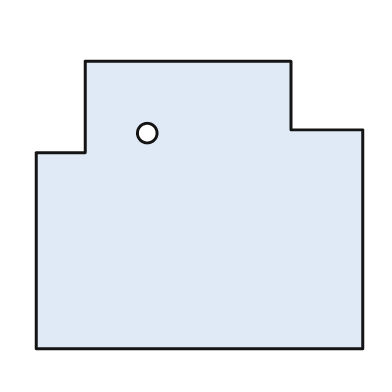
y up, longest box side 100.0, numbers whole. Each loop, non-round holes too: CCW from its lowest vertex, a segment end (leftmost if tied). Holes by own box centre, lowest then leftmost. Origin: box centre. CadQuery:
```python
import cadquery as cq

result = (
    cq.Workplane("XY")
    .moveTo(-50.0, -44.0)
    .lineTo(50.0, -44.0)
    .lineTo(50.0, 23.0)
    .lineTo(28.0, 23.0)
    .lineTo(28.0, 44.0)
    .lineTo(-35.0, 44.0)
    .lineTo(-35.0, 16.0)
    .lineTo(-50.0, 16.0)
    .close()
    .moveTo(-16.0, 22.0)
    .circle(3.0)
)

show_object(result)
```